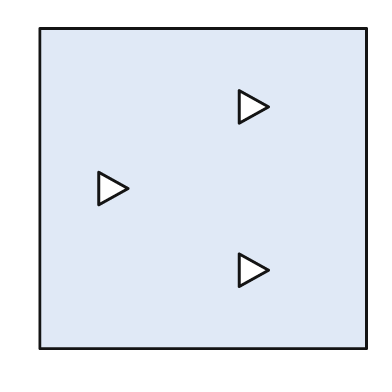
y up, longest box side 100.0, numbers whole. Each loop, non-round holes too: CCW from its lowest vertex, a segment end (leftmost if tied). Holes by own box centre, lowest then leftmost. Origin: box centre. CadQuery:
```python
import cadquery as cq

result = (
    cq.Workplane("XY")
    .moveTo(-50.0, -49.0)
    .lineTo(50.0, -49.0)
    .lineTo(50.0, 49.0)
    .lineTo(-50.0, 49.0)
    .close()
    .moveTo(11.0, -30.0)
    .lineTo(20.0, -25.0)
    .lineTo(11.0, -20.0)
    .close()
    .moveTo(-32.0, -5.0)
    .lineTo(-23.0, 0.0)
    .lineTo(-32.0, 5.0)
    .close()
    .moveTo(11.0, 20.0)
    .lineTo(20.0, 25.0)
    .lineTo(11.0, 30.0)
    .close()
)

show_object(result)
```